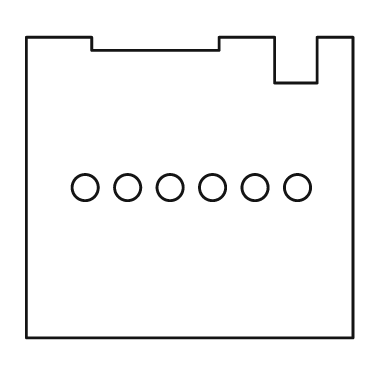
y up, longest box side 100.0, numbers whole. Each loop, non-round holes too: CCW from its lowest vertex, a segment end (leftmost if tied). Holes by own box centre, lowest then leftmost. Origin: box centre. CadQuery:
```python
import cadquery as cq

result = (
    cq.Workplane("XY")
    .moveTo(-50.0, -46.0)
    .lineTo(50.0, -46.0)
    .lineTo(50.0, 46.0)
    .lineTo(39.0, 46.0)
    .lineTo(39.0, 32.0)
    .lineTo(26.0, 32.0)
    .lineTo(26.0, 46.0)
    .lineTo(9.0, 46.0)
    .lineTo(9.0, 42.0)
    .lineTo(-30.0, 42.0)
    .lineTo(-30.0, 46.0)
    .lineTo(-50.0, 46.0)
    .close()
    .moveTo(-32.0, 0.0)
    .circle(4.0)
    .moveTo(-19.0, 0.0)
    .circle(4.0)
    .moveTo(-6.0, 0.0)
    .circle(4.0)
    .moveTo(7.0, 0.0)
    .circle(4.0)
    .moveTo(20.0, 0.0)
    .circle(4.0)
    .moveTo(33.0, 0.0)
    .circle(4.0)
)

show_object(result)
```